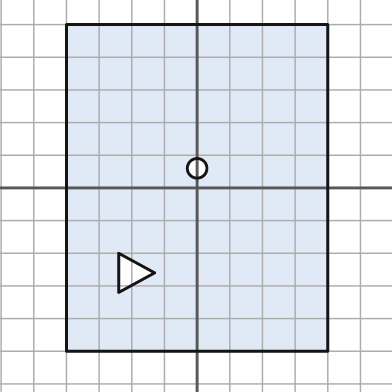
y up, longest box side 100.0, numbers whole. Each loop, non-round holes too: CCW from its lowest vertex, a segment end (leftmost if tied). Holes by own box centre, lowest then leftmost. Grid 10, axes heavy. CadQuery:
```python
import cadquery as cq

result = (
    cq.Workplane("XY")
    .moveTo(-40.0, -50.0)
    .lineTo(40.0, -50.0)
    .lineTo(40.0, 50.0)
    .lineTo(-40.0, 50.0)
    .close()
    .moveTo(-24.0, -32.0)
    .lineTo(-13.0, -26.0)
    .lineTo(-24.0, -20.0)
    .close()
    .moveTo(0.0, 6.0)
    .circle(3.0)
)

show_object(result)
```